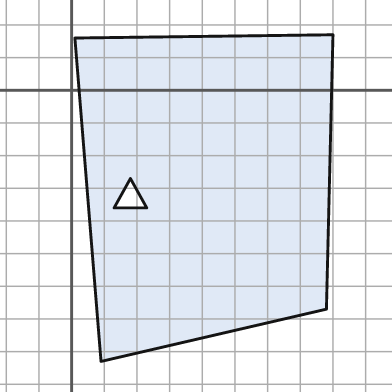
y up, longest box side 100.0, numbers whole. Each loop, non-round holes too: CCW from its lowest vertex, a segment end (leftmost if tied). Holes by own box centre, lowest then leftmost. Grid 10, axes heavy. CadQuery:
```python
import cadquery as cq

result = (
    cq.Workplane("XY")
    .moveTo(9.0, -83.0)
    .lineTo(78.0, -67.0)
    .lineTo(80.0, 17.0)
    .lineTo(1.0, 16.0)
    .close()
    .moveTo(13.0, -36.0)
    .lineTo(23.0, -36.0)
    .lineTo(18.0, -27.0)
    .close()
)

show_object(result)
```